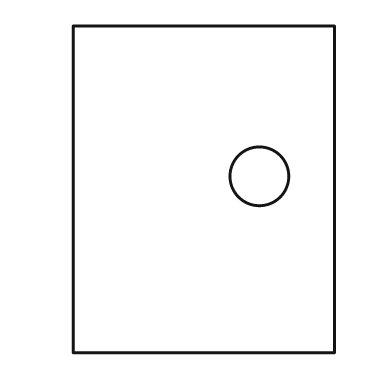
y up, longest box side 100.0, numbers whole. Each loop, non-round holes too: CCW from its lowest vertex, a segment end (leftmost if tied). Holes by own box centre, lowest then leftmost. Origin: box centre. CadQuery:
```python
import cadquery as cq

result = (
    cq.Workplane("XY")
    .moveTo(-40.0, -50.0)
    .lineTo(40.0, -50.0)
    .lineTo(40.0, 50.0)
    .lineTo(-40.0, 50.0)
    .close()
    .moveTo(17.0, 4.0)
    .circle(9.0)
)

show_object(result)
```